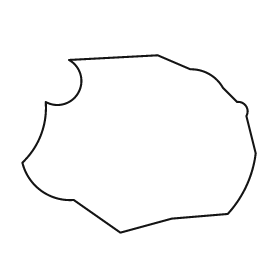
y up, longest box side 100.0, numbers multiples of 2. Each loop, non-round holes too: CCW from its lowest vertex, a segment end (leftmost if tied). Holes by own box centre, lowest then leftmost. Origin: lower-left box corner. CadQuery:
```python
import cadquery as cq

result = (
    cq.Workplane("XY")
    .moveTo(42.0, 0.0)
    .lineTo(64.0, 6.0)
    .lineTo(88.0, 8.0)
    .threePointArc((96.0, 20.0), (100.0, 34.0))
    .lineTo(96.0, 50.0)
    .threePointArc((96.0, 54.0), (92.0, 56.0))
    .lineTo(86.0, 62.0)
    .threePointArc((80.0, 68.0), (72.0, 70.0))
    .lineTo(58.0, 76.0)
    .lineTo(20.0, 74.0)
    .threePointArc((24.0, 60.0), (10.0, 56.0))
    .threePointArc((8.0, 42.0), (0.0, 30.0))
    .threePointArc((8.0, 18.0), (22.0, 14.0))
    .close()
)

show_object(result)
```